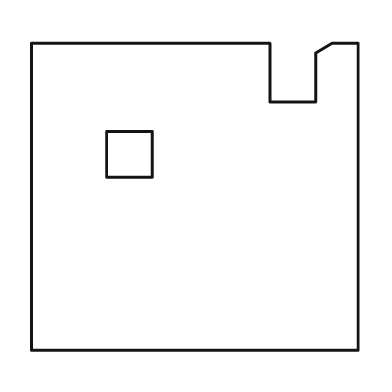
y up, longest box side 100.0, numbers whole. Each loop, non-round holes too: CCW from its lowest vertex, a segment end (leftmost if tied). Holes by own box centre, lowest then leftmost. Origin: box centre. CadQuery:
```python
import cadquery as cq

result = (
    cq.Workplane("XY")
    .moveTo(-50.0, -47.0)
    .lineTo(50.0, -47.0)
    .lineTo(50.0, 47.0)
    .lineTo(42.0, 47.0)
    .lineTo(37.0, 44.0)
    .lineTo(37.0, 29.0)
    .lineTo(23.0, 29.0)
    .lineTo(23.0, 47.0)
    .lineTo(-50.0, 47.0)
    .close()
    .moveTo(-27.0, 6.0)
    .lineTo(-13.0, 6.0)
    .lineTo(-13.0, 20.0)
    .lineTo(-27.0, 20.0)
    .close()
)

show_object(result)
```